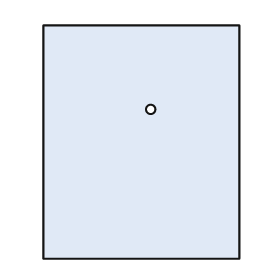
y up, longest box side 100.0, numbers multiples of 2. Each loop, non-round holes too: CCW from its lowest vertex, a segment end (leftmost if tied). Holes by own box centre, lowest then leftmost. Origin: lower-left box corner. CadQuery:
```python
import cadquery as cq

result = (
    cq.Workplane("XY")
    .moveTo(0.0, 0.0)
    .lineTo(84.0, 0.0)
    .lineTo(84.0, 100.0)
    .lineTo(0.0, 100.0)
    .close()
    .moveTo(46.0, 64.0)
    .circle(2.0)
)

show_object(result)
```